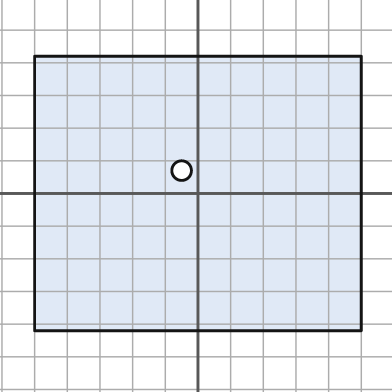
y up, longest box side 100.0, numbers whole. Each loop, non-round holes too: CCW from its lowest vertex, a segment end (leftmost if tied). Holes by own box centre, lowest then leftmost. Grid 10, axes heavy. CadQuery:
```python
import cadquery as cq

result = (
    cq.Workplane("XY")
    .moveTo(-50.0, -42.0)
    .lineTo(50.0, -42.0)
    .lineTo(50.0, 42.0)
    .lineTo(-50.0, 42.0)
    .close()
    .moveTo(-5.0, 7.0)
    .circle(3.0)
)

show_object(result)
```